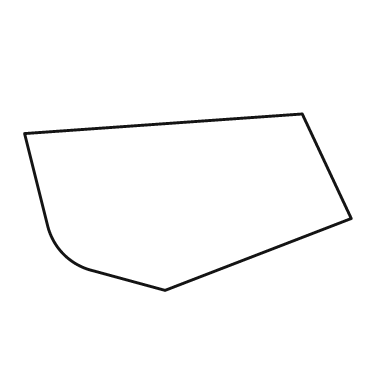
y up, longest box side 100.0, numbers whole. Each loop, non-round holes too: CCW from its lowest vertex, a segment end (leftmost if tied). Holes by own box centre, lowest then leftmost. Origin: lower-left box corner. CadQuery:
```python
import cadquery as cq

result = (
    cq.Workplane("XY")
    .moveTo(43.0, 0.0)
    .lineTo(100.0, 22.0)
    .lineTo(85.0, 54.0)
    .lineTo(0.0, 48.0)
    .lineTo(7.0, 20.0)
    .threePointArc((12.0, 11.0), (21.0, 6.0))
    .close()
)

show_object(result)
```